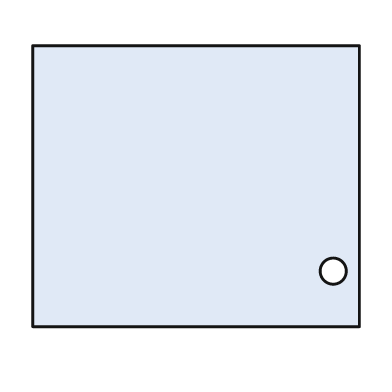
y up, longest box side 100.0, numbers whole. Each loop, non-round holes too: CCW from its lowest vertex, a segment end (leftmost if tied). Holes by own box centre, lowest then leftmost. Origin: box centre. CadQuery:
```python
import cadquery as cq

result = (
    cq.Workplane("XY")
    .moveTo(-50.0, -43.0)
    .lineTo(50.0, -43.0)
    .lineTo(50.0, 43.0)
    .lineTo(-50.0, 43.0)
    .close()
    .moveTo(42.0, -26.0)
    .circle(4.0)
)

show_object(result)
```